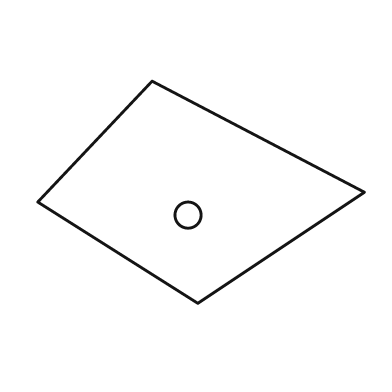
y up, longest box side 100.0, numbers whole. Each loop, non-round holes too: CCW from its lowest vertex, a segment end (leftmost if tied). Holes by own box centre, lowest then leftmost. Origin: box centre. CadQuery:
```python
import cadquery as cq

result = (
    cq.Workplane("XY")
    .moveTo(-1.0, -34.0)
    .lineTo(50.0, 0.0)
    .lineTo(-15.0, 34.0)
    .lineTo(-50.0, -3.0)
    .close()
    .moveTo(-4.0, -7.0)
    .circle(4.0)
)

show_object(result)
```